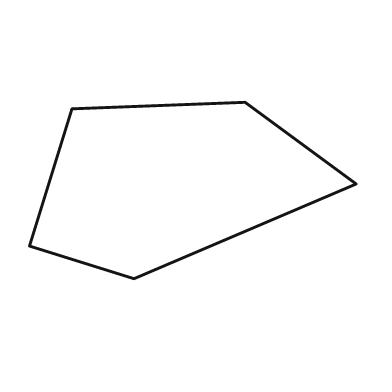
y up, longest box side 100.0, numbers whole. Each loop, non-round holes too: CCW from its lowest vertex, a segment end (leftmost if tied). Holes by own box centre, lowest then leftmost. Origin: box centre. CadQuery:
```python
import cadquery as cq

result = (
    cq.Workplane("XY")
    .moveTo(-18.0, -27.0)
    .lineTo(50.0, 2.0)
    .lineTo(16.0, 27.0)
    .lineTo(-37.0, 25.0)
    .lineTo(-50.0, -17.0)
    .close()
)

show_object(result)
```